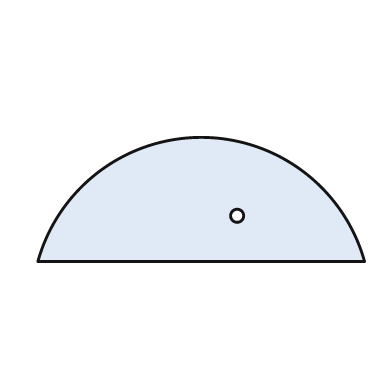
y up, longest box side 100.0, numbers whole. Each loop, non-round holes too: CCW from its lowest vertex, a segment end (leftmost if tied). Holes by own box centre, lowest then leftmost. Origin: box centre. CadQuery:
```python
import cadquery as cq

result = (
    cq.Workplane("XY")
    .moveTo(-50.0, -19.0)
    .lineTo(50.0, -19.0)
    .threePointArc((0.0, 19.0), (-50.0, -19.0))
    .close()
    .moveTo(11.0, -5.0)
    .circle(2.0)
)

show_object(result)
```